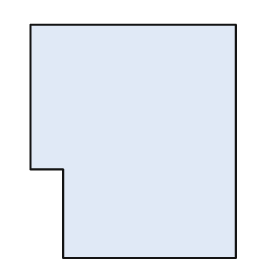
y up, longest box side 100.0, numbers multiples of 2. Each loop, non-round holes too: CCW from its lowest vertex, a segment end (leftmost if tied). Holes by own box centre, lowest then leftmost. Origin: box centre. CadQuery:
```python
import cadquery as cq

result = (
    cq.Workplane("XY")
    .moveTo(-30.0, -50.0)
    .lineTo(44.0, -50.0)
    .lineTo(44.0, 50.0)
    .lineTo(-44.0, 50.0)
    .lineTo(-44.0, -12.0)
    .lineTo(-30.0, -12.0)
    .close()
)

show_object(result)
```